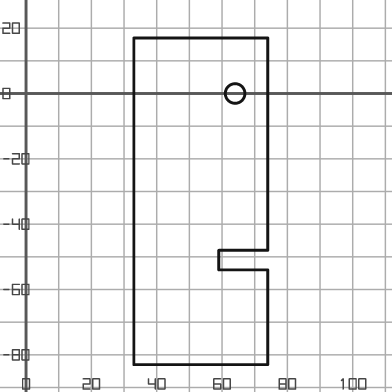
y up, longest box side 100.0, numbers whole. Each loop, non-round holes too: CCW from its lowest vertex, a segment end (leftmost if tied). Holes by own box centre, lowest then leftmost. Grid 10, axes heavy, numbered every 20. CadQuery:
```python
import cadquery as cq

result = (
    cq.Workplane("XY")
    .moveTo(33.0, -83.0)
    .lineTo(74.0, -83.0)
    .lineTo(74.0, -54.0)
    .lineTo(59.0, -54.0)
    .lineTo(59.0, -48.0)
    .lineTo(74.0, -48.0)
    .lineTo(74.0, 17.0)
    .lineTo(33.0, 17.0)
    .close()
    .moveTo(64.0, 0.0)
    .circle(3.0)
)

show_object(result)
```